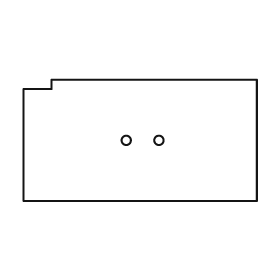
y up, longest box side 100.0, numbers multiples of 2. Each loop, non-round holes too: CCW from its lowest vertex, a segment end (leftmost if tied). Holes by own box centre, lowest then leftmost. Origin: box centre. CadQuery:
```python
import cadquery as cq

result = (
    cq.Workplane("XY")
    .moveTo(-50.0, -26.0)
    .lineTo(50.0, -26.0)
    .lineTo(50.0, 26.0)
    .lineTo(-38.0, 26.0)
    .lineTo(-38.0, 22.0)
    .lineTo(-50.0, 22.0)
    .close()
    .moveTo(-6.0, 0.0)
    .circle(2.0)
    .moveTo(8.0, 0.0)
    .circle(2.0)
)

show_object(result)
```